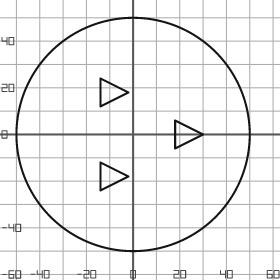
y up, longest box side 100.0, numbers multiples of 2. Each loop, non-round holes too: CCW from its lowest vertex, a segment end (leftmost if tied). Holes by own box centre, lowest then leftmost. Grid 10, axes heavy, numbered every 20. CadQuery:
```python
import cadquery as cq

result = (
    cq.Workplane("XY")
    .moveTo(0.0, 0.0)
    .circle(50.0)
    .moveTo(-14.0, -24.0)
    .lineTo(-2.0, -18.0)
    .lineTo(-14.0, -12.0)
    .close()
    .moveTo(18.0, -6.0)
    .lineTo(30.0, 0.0)
    .lineTo(18.0, 6.0)
    .close()
    .moveTo(-14.0, 12.0)
    .lineTo(-2.0, 18.0)
    .lineTo(-14.0, 24.0)
    .close()
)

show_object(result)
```